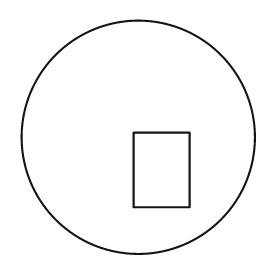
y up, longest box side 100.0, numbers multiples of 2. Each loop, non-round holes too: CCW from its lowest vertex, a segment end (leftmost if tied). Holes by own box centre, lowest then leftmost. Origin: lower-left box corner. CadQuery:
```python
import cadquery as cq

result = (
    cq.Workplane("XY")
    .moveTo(50.0, 50.0)
    .circle(50.0)
    .moveTo(48.0, 20.0)
    .lineTo(72.0, 20.0)
    .lineTo(72.0, 52.0)
    .lineTo(48.0, 52.0)
    .close()
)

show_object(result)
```